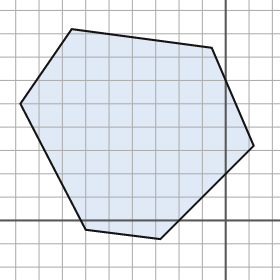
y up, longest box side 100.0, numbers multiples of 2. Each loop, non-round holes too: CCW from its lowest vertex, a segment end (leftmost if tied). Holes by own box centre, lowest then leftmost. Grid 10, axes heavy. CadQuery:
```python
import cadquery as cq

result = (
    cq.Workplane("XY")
    .moveTo(-28.0, -8.0)
    .lineTo(12.0, 32.0)
    .lineTo(-6.0, 74.0)
    .lineTo(-66.0, 82.0)
    .lineTo(-88.0, 50.0)
    .lineTo(-60.0, -4.0)
    .close()
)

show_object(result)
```